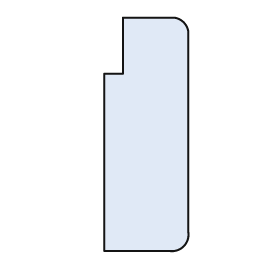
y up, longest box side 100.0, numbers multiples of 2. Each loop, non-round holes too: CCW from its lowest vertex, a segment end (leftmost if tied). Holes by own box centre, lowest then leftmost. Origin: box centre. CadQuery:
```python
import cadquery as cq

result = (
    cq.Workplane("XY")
    .moveTo(-18.0, -50.0)
    .lineTo(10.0, -50.0)
    .threePointArc((16.0, -48.0), (18.0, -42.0))
    .lineTo(18.0, 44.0)
    .threePointArc((16.0, 48.0), (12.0, 50.0))
    .lineTo(-10.0, 50.0)
    .lineTo(-10.0, 26.0)
    .lineTo(-18.0, 26.0)
    .close()
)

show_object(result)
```